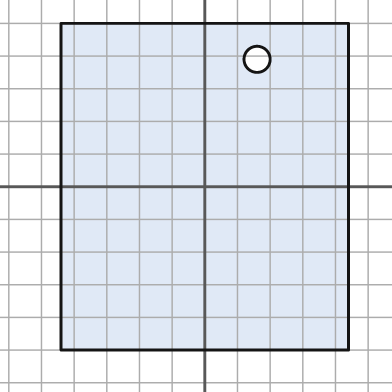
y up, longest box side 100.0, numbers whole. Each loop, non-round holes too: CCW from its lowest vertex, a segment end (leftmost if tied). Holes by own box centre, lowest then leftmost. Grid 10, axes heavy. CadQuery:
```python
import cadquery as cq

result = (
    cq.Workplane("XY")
    .moveTo(-44.0, -50.0)
    .lineTo(44.0, -50.0)
    .lineTo(44.0, 50.0)
    .lineTo(-44.0, 50.0)
    .close()
    .moveTo(16.0, 39.0)
    .circle(4.0)
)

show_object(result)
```